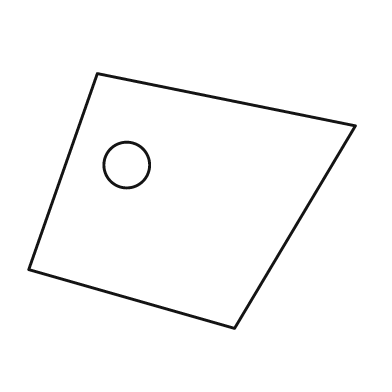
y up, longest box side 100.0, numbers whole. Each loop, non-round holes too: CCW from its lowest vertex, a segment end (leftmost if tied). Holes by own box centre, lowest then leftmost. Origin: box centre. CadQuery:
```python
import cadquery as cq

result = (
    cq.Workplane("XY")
    .moveTo(13.0, -39.0)
    .lineTo(50.0, 23.0)
    .lineTo(-29.0, 39.0)
    .lineTo(-50.0, -21.0)
    .close()
    .moveTo(-20.0, 11.0)
    .circle(7.0)
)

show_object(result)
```